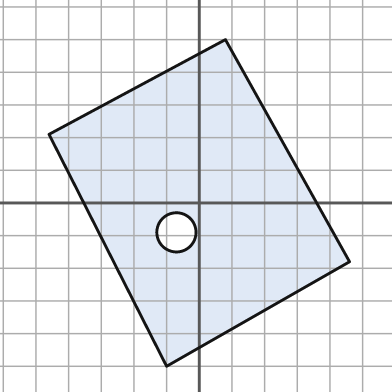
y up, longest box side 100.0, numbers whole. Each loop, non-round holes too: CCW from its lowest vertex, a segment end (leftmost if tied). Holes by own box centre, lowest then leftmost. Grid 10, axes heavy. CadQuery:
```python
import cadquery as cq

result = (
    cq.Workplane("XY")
    .moveTo(-10.0, -50.0)
    .lineTo(46.0, -18.0)
    .lineTo(8.0, 50.0)
    .lineTo(-46.0, 21.0)
    .close()
    .moveTo(-7.0, -9.0)
    .circle(6.0)
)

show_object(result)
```